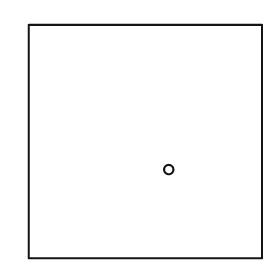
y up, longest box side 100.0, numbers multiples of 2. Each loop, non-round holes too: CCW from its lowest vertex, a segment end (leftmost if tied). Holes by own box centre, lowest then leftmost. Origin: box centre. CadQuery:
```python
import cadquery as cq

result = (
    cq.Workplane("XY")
    .moveTo(-50.0, -50.0)
    .lineTo(50.0, -50.0)
    .lineTo(50.0, 50.0)
    .lineTo(-50.0, 50.0)
    .close()
    .moveTo(10.0, -12.0)
    .circle(2.0)
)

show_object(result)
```